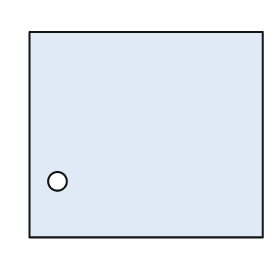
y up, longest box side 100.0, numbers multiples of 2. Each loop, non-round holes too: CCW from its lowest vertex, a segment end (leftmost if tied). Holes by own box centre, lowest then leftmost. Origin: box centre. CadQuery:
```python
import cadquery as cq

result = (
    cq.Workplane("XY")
    .moveTo(-50.0, -44.0)
    .lineTo(50.0, -44.0)
    .lineTo(50.0, 44.0)
    .lineTo(-50.0, 44.0)
    .close()
    .moveTo(-38.0, -20.0)
    .circle(4.0)
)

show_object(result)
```